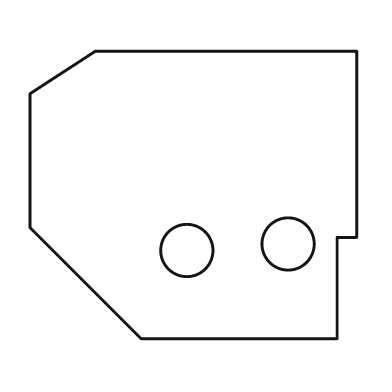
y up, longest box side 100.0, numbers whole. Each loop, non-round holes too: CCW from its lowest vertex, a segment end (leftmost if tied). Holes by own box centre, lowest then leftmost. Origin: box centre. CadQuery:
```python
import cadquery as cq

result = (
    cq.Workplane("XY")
    .moveTo(-16.0, -44.0)
    .lineTo(44.0, -44.0)
    .lineTo(44.0, -13.0)
    .lineTo(50.0, -13.0)
    .lineTo(50.0, 44.0)
    .lineTo(-30.0, 44.0)
    .lineTo(-50.0, 31.0)
    .lineTo(-50.0, -10.0)
    .close()
    .moveTo(-2.0, -17.0)
    .circle(8.0)
    .moveTo(29.0, -15.0)
    .circle(8.0)
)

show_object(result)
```